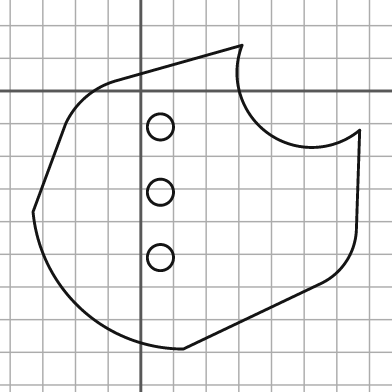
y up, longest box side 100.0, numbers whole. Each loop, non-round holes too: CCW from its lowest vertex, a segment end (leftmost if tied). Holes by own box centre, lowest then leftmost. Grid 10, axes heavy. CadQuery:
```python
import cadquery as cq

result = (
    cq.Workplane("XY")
    .moveTo(13.0, -79.0)
    .lineTo(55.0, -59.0)
    .threePointArc((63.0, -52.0), (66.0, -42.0))
    .lineTo(67.0, -12.0)
    .threePointArc((39.0, -13.0), (31.0, 14.0))
    .lineTo(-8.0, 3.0)
    .threePointArc((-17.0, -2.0), (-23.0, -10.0))
    .lineTo(-33.0, -37.0)
    .threePointArc((-18.0, -67.0), (13.0, -79.0))
    .close()
    .moveTo(6.0, -51.0)
    .circle(4.0)
    .moveTo(6.0, -31.0)
    .circle(4.0)
    .moveTo(6.0, -11.0)
    .circle(4.0)
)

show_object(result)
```